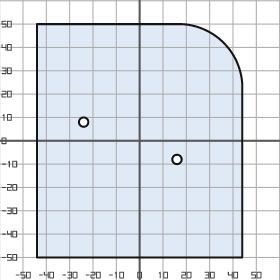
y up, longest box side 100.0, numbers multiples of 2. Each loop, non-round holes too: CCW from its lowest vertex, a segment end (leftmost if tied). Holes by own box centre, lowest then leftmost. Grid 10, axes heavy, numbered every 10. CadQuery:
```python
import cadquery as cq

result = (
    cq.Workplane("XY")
    .moveTo(-44.0, -50.0)
    .lineTo(44.0, -50.0)
    .lineTo(44.0, 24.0)
    .threePointArc((36.0, 42.0), (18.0, 50.0))
    .lineTo(-44.0, 50.0)
    .close()
    .moveTo(16.0, -8.0)
    .circle(2.0)
    .moveTo(-24.0, 8.0)
    .circle(2.0)
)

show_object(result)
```